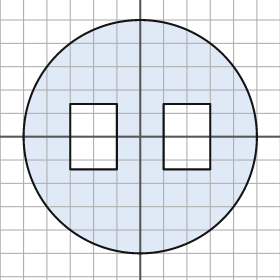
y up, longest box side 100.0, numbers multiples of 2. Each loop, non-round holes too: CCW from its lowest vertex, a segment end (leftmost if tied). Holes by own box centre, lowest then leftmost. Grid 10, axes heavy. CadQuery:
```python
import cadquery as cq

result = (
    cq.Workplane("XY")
    .moveTo(0.0, 0.0)
    .circle(50.0)
    .moveTo(-30.0, -14.0)
    .lineTo(-10.0, -14.0)
    .lineTo(-10.0, 14.0)
    .lineTo(-30.0, 14.0)
    .close()
    .moveTo(10.0, -14.0)
    .lineTo(30.0, -14.0)
    .lineTo(30.0, 14.0)
    .lineTo(10.0, 14.0)
    .close()
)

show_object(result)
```